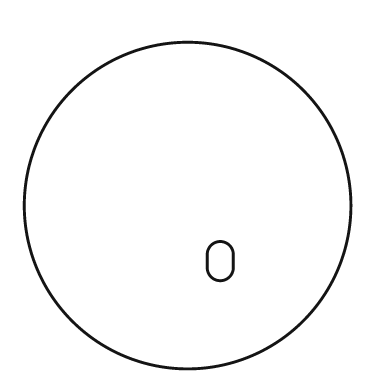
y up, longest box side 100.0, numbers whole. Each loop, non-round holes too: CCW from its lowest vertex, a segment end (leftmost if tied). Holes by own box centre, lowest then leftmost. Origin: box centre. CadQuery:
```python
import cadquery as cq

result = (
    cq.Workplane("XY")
    .moveTo(0.0, 0.0)
    .circle(50.0)
    .moveTo(6.0, -19.0)
    .threePointArc((10.0, -23.0), (14.0, -19.0))
    .lineTo(14.0, -15.0)
    .threePointArc((10.0, -11.0), (6.0, -15.0))
    .close()
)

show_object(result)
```